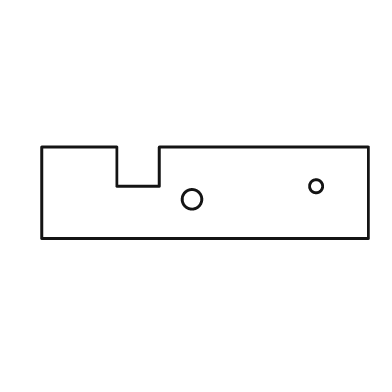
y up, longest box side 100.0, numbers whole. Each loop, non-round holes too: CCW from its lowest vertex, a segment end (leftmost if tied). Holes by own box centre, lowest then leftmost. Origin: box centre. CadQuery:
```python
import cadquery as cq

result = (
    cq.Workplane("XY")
    .moveTo(-50.0, -14.0)
    .lineTo(50.0, -14.0)
    .lineTo(50.0, 14.0)
    .lineTo(-14.0, 14.0)
    .lineTo(-14.0, 2.0)
    .lineTo(-27.0, 2.0)
    .lineTo(-27.0, 14.0)
    .lineTo(-50.0, 14.0)
    .close()
    .moveTo(-4.0, -2.0)
    .circle(3.0)
    .moveTo(34.0, 2.0)
    .circle(2.0)
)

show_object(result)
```